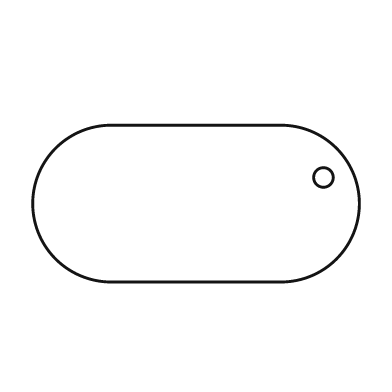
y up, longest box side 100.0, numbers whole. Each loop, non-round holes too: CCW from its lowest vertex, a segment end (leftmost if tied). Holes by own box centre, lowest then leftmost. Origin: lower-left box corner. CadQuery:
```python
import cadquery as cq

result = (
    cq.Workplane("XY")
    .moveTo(24.0, 0.0)
    .lineTo(76.0, 0.0)
    .threePointArc((100.0, 24.0), (76.0, 48.0))
    .lineTo(24.0, 48.0)
    .threePointArc((0.0, 24.0), (24.0, 0.0))
    .close()
    .moveTo(89.0, 32.0)
    .circle(3.0)
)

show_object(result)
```